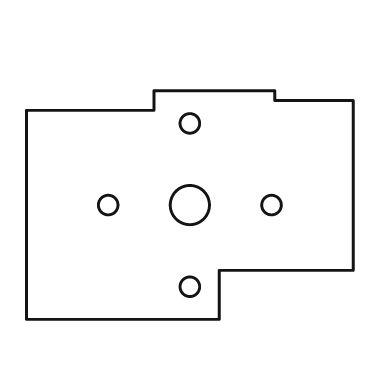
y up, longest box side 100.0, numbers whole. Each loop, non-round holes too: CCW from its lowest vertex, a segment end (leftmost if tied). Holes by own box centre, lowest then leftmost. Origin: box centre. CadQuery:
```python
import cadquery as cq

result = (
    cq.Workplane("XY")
    .moveTo(-50.0, -35.0)
    .lineTo(9.0, -35.0)
    .lineTo(9.0, -20.0)
    .lineTo(50.0, -20.0)
    .lineTo(50.0, 32.0)
    .lineTo(26.0, 32.0)
    .lineTo(26.0, 35.0)
    .lineTo(-11.0, 35.0)
    .lineTo(-11.0, 29.0)
    .lineTo(-50.0, 29.0)
    .close()
    .moveTo(0.0, -25.0)
    .circle(3.0)
    .moveTo(-25.0, 0.0)
    .circle(3.0)
    .moveTo(0.0, 0.0)
    .circle(6.0)
    .moveTo(25.0, 0.0)
    .circle(3.0)
    .moveTo(0.0, 25.0)
    .circle(3.0)
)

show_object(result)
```